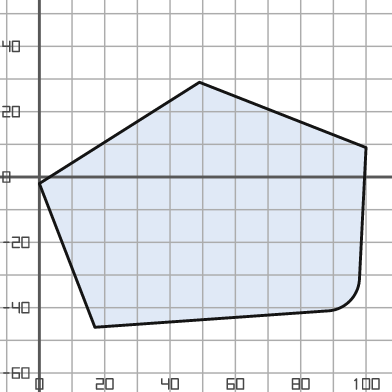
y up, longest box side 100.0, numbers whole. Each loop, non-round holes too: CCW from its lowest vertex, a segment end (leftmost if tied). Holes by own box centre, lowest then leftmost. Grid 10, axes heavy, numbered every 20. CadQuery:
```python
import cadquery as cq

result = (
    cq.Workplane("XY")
    .moveTo(17.0, -46.0)
    .lineTo(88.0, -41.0)
    .threePointArc((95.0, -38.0), (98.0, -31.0))
    .lineTo(100.0, 9.0)
    .lineTo(49.0, 29.0)
    .lineTo(0.0, -2.0)
    .close()
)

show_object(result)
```